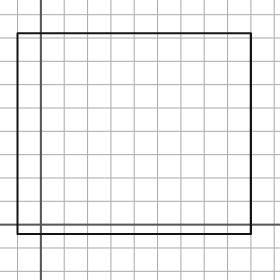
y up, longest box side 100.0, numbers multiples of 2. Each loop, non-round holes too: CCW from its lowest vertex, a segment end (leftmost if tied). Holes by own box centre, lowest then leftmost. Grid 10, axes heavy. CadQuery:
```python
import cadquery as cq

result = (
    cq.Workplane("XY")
    .moveTo(-10.0, -4.0)
    .lineTo(90.0, -4.0)
    .lineTo(90.0, 82.0)
    .lineTo(-10.0, 82.0)
    .close()
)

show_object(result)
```